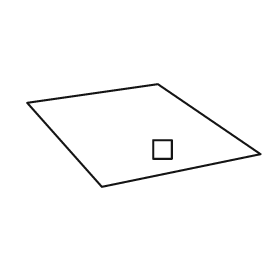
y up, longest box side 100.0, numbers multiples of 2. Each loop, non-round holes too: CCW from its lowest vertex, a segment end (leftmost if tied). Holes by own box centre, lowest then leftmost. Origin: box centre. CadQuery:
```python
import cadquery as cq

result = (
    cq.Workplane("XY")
    .moveTo(-18.0, -22.0)
    .lineTo(50.0, -8.0)
    .lineTo(6.0, 22.0)
    .lineTo(-50.0, 14.0)
    .close()
    .moveTo(4.0, -10.0)
    .lineTo(12.0, -10.0)
    .lineTo(12.0, -2.0)
    .lineTo(4.0, -2.0)
    .close()
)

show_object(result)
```